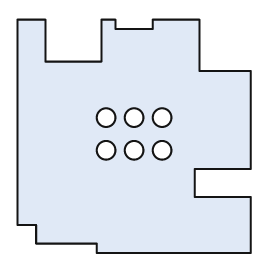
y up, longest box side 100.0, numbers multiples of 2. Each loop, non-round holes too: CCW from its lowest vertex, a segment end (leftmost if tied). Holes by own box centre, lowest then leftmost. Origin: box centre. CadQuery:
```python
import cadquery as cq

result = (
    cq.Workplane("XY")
    .moveTo(-16.0, -50.0)
    .lineTo(50.0, -50.0)
    .lineTo(50.0, -26.0)
    .lineTo(26.0, -26.0)
    .lineTo(26.0, -14.0)
    .lineTo(50.0, -14.0)
    .lineTo(50.0, 28.0)
    .lineTo(28.0, 28.0)
    .lineTo(28.0, 50.0)
    .lineTo(8.0, 50.0)
    .lineTo(8.0, 46.0)
    .lineTo(-8.0, 46.0)
    .lineTo(-8.0, 50.0)
    .lineTo(-14.0, 50.0)
    .lineTo(-14.0, 32.0)
    .lineTo(-38.0, 32.0)
    .lineTo(-38.0, 50.0)
    .lineTo(-50.0, 50.0)
    .lineTo(-50.0, -38.0)
    .lineTo(-42.0, -38.0)
    .lineTo(-42.0, -46.0)
    .lineTo(-16.0, -46.0)
    .close()
    .moveTo(-12.0, -6.0)
    .circle(4.0)
    .moveTo(0.0, -6.0)
    .circle(4.0)
    .moveTo(12.0, -6.0)
    .circle(4.0)
    .moveTo(-12.0, 8.0)
    .circle(4.0)
    .moveTo(0.0, 8.0)
    .circle(4.0)
    .moveTo(12.0, 8.0)
    .circle(4.0)
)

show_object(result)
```